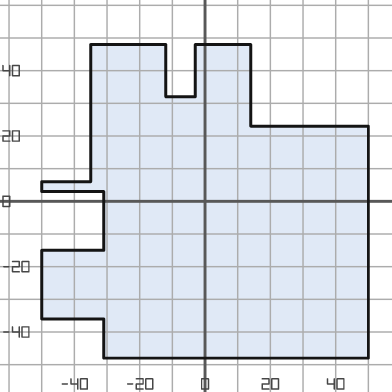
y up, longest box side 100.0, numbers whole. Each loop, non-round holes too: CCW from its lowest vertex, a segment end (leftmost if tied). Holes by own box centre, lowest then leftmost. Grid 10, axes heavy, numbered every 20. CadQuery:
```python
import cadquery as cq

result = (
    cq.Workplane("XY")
    .moveTo(-31.0, -48.0)
    .lineTo(50.0, -48.0)
    .lineTo(50.0, 23.0)
    .lineTo(14.0, 23.0)
    .lineTo(14.0, 48.0)
    .lineTo(-3.0, 48.0)
    .lineTo(-3.0, 32.0)
    .lineTo(-12.0, 32.0)
    .lineTo(-12.0, 48.0)
    .lineTo(-35.0, 48.0)
    .lineTo(-35.0, 6.0)
    .lineTo(-50.0, 6.0)
    .lineTo(-50.0, 3.0)
    .lineTo(-31.0, 3.0)
    .lineTo(-31.0, -15.0)
    .lineTo(-50.0, -15.0)
    .lineTo(-50.0, -36.0)
    .lineTo(-31.0, -36.0)
    .close()
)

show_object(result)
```